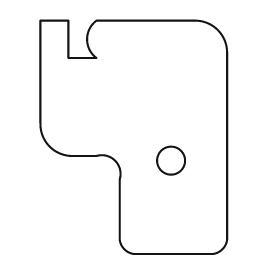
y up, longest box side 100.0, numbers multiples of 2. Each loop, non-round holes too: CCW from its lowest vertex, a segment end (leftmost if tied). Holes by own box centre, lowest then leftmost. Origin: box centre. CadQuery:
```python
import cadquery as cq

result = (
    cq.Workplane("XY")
    .moveTo(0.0, -50.0)
    .lineTo(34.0, -50.0)
    .threePointArc((38.0, -48.0), (40.0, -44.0))
    .lineTo(40.0, 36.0)
    .threePointArc((36.0, 46.0), (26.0, 50.0))
    .lineTo(-16.0, 50.0)
    .threePointArc((-20.0, 42.0), (-16.0, 34.0))
    .lineTo(-28.0, 34.0)
    .lineTo(-28.0, 50.0)
    .lineTo(-40.0, 50.0)
    .lineTo(-40.0, 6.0)
    .threePointArc((-36.0, -4.0), (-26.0, -8.0))
    .lineTo(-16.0, -8.0)
    .threePointArc((-8.0, -10.0), (-6.0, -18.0))
    .lineTo(-6.0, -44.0)
    .threePointArc((-4.0, -48.0), (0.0, -50.0))
    .close()
    .moveTo(16.0, -10.0)
    .circle(6.0)
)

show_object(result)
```